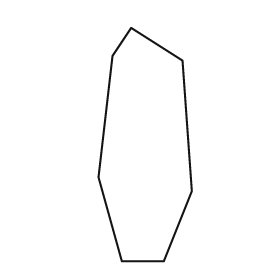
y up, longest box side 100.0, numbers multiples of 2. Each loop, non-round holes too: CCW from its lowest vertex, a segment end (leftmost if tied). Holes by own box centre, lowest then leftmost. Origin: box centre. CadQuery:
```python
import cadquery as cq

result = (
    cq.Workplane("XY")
    .moveTo(-10.0, -50.0)
    .lineTo(8.0, -50.0)
    .lineTo(20.0, -20.0)
    .lineTo(16.0, 36.0)
    .lineTo(-6.0, 50.0)
    .lineTo(-14.0, 38.0)
    .lineTo(-20.0, -14.0)
    .close()
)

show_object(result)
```